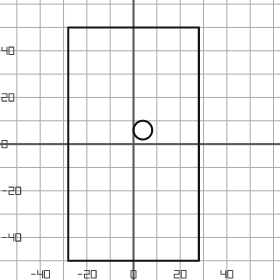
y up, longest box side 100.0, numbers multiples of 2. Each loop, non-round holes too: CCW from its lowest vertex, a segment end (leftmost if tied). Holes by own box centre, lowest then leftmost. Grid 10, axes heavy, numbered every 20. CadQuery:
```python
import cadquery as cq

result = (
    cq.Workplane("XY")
    .moveTo(-28.0, -50.0)
    .lineTo(28.0, -50.0)
    .lineTo(28.0, 50.0)
    .lineTo(-28.0, 50.0)
    .close()
    .moveTo(4.0, 6.0)
    .circle(4.0)
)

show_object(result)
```